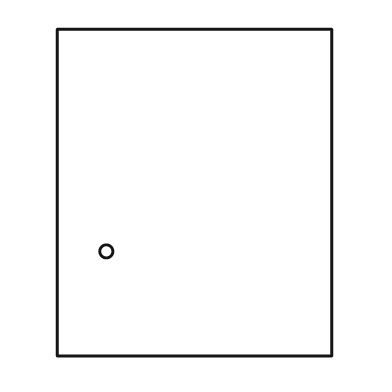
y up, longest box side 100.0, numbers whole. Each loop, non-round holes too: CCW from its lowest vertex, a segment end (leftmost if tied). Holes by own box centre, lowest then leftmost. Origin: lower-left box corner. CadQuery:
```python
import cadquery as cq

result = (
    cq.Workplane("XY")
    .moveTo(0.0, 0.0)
    .lineTo(84.0, 0.0)
    .lineTo(84.0, 100.0)
    .lineTo(0.0, 100.0)
    .close()
    .moveTo(15.0, 32.0)
    .circle(2.0)
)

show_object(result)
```